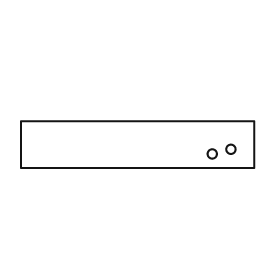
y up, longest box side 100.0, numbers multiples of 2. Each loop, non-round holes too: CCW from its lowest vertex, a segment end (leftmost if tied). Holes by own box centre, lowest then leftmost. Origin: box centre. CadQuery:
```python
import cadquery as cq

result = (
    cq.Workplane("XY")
    .moveTo(-50.0, -10.0)
    .lineTo(50.0, -10.0)
    .lineTo(50.0, 10.0)
    .lineTo(-50.0, 10.0)
    .close()
    .moveTo(32.0, -4.0)
    .circle(2.0)
    .moveTo(40.0, -2.0)
    .circle(2.0)
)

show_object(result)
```